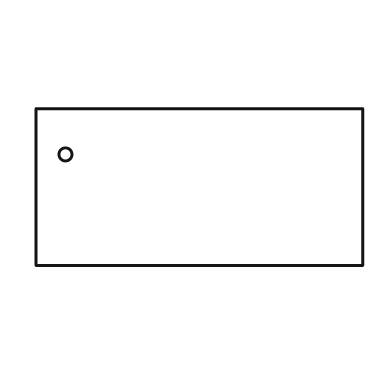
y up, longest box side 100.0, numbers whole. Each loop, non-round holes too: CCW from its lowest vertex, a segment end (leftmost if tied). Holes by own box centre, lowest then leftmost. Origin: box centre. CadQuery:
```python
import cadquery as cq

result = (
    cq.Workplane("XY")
    .moveTo(-50.0, -24.0)
    .lineTo(50.0, -24.0)
    .lineTo(50.0, 24.0)
    .lineTo(-50.0, 24.0)
    .close()
    .moveTo(-41.0, 10.0)
    .circle(2.0)
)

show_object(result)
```